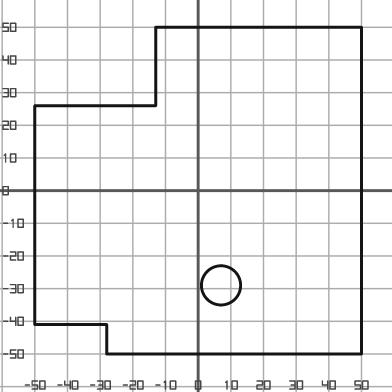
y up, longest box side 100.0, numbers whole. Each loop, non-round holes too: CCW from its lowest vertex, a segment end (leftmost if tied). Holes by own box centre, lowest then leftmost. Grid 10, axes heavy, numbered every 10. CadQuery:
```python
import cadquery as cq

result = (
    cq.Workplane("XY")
    .moveTo(-28.0, -50.0)
    .lineTo(50.0, -50.0)
    .lineTo(50.0, 50.0)
    .lineTo(-13.0, 50.0)
    .lineTo(-13.0, 26.0)
    .lineTo(-50.0, 26.0)
    .lineTo(-50.0, -41.0)
    .lineTo(-28.0, -41.0)
    .close()
    .moveTo(7.0, -29.0)
    .circle(6.0)
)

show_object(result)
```